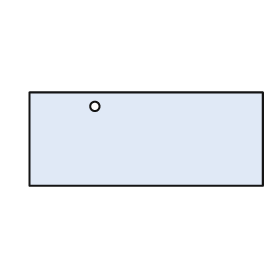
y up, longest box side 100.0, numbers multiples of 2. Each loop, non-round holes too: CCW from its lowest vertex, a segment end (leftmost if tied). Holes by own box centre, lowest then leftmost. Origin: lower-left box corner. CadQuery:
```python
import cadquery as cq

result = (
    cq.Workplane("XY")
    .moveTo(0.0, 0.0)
    .lineTo(100.0, 0.0)
    .lineTo(100.0, 40.0)
    .lineTo(0.0, 40.0)
    .close()
    .moveTo(28.0, 34.0)
    .circle(2.0)
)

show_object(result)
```